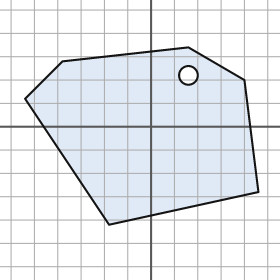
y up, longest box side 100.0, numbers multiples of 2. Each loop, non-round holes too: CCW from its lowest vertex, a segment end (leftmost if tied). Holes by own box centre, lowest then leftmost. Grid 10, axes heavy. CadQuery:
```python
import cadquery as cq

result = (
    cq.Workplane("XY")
    .moveTo(-18.0, -42.0)
    .lineTo(46.0, -28.0)
    .lineTo(40.0, 20.0)
    .lineTo(16.0, 34.0)
    .lineTo(-38.0, 28.0)
    .lineTo(-54.0, 12.0)
    .close()
    .moveTo(16.0, 22.0)
    .circle(4.0)
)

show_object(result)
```